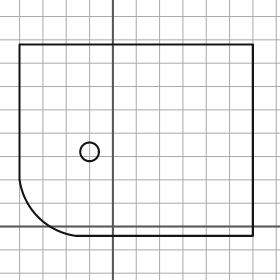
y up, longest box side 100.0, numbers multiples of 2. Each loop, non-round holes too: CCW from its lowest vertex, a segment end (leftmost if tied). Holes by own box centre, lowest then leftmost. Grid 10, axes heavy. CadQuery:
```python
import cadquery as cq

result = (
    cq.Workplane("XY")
    .moveTo(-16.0, -4.0)
    .lineTo(60.0, -4.0)
    .lineTo(60.0, 78.0)
    .lineTo(-40.0, 78.0)
    .lineTo(-40.0, 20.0)
    .threePointArc((-32.0, 4.0), (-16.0, -4.0))
    .close()
    .moveTo(-10.0, 32.0)
    .circle(4.0)
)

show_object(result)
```